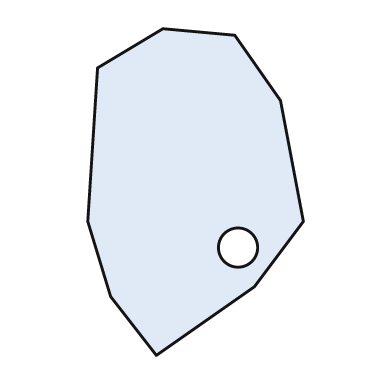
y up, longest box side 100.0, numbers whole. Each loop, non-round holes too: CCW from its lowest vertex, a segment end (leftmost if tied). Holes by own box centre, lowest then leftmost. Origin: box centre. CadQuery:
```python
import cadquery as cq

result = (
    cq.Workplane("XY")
    .moveTo(-12.0, -50.0)
    .lineTo(18.0, -29.0)
    .lineTo(33.0, -9.0)
    .lineTo(26.0, 28.0)
    .lineTo(12.0, 48.0)
    .lineTo(-10.0, 50.0)
    .lineTo(-30.0, 38.0)
    .lineTo(-33.0, -9.0)
    .lineTo(-26.0, -32.0)
    .close()
    .moveTo(13.0, -17.0)
    .circle(6.0)
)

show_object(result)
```